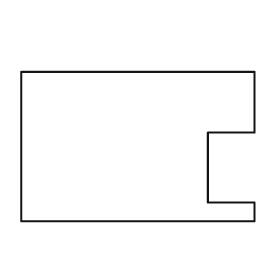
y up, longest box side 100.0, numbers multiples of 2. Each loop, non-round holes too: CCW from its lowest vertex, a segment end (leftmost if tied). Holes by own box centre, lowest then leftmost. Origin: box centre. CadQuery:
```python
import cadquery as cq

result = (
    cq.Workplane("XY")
    .moveTo(-50.0, -32.0)
    .lineTo(50.0, -32.0)
    .lineTo(50.0, -24.0)
    .lineTo(30.0, -24.0)
    .lineTo(30.0, 6.0)
    .lineTo(50.0, 6.0)
    .lineTo(50.0, 32.0)
    .lineTo(-50.0, 32.0)
    .close()
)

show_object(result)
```